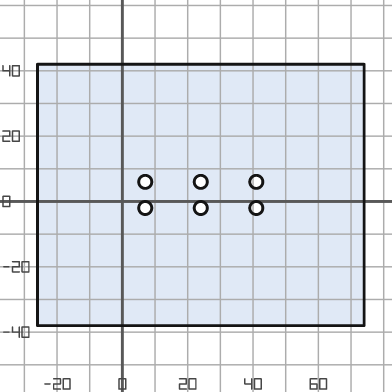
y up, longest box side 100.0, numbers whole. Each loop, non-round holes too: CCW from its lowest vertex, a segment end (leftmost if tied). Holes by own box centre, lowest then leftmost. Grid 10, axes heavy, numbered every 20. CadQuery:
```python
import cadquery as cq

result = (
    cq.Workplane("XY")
    .moveTo(-26.0, -38.0)
    .lineTo(74.0, -38.0)
    .lineTo(74.0, 42.0)
    .lineTo(-26.0, 42.0)
    .close()
    .moveTo(7.0, -2.0)
    .circle(2.0)
    .moveTo(24.0, -2.0)
    .circle(2.0)
    .moveTo(41.0, -2.0)
    .circle(2.0)
    .moveTo(7.0, 6.0)
    .circle(2.0)
    .moveTo(24.0, 6.0)
    .circle(2.0)
    .moveTo(41.0, 6.0)
    .circle(2.0)
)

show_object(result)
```